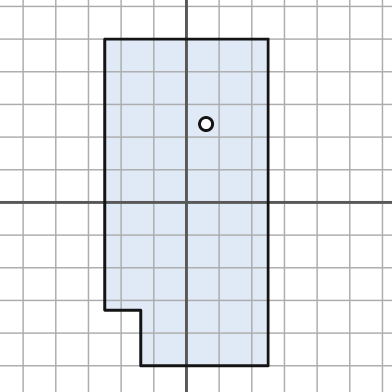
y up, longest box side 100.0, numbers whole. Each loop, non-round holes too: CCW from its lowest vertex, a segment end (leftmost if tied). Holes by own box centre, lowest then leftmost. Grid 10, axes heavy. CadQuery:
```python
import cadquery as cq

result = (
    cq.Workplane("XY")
    .moveTo(-14.0, -50.0)
    .lineTo(25.0, -50.0)
    .lineTo(25.0, 50.0)
    .lineTo(-25.0, 50.0)
    .lineTo(-25.0, -33.0)
    .lineTo(-14.0, -33.0)
    .close()
    .moveTo(6.0, 24.0)
    .circle(2.0)
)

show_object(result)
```